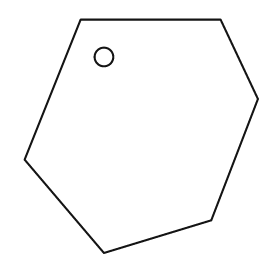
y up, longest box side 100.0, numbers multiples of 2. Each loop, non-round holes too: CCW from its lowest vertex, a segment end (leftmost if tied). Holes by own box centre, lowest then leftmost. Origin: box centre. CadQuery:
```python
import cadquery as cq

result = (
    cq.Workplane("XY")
    .moveTo(-16.0, -50.0)
    .lineTo(30.0, -36.0)
    .lineTo(50.0, 16.0)
    .lineTo(34.0, 50.0)
    .lineTo(-26.0, 50.0)
    .lineTo(-50.0, -10.0)
    .close()
    .moveTo(-16.0, 34.0)
    .circle(4.0)
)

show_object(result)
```